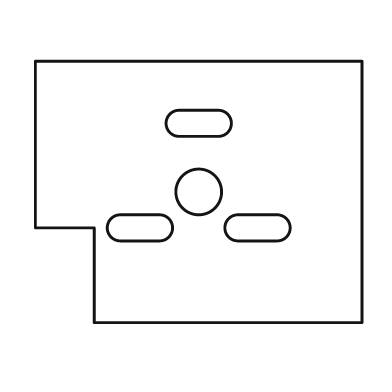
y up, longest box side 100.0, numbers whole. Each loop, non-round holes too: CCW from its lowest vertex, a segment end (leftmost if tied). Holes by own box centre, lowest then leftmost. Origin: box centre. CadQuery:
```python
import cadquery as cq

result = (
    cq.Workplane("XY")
    .moveTo(-32.0, -40.0)
    .lineTo(50.0, -40.0)
    .lineTo(50.0, 40.0)
    .lineTo(-50.0, 40.0)
    .lineTo(-50.0, -11.0)
    .lineTo(-32.0, -11.0)
    .close()
    .moveTo(-24.0, -15.0)
    .lineTo(-12.0, -15.0)
    .threePointArc((-8.0, -11.0), (-12.0, -7.0))
    .lineTo(-24.0, -7.0)
    .threePointArc((-28.0, -11.0), (-24.0, -15.0))
    .close()
    .moveTo(12.0, -15.0)
    .lineTo(24.0, -15.0)
    .threePointArc((28.0, -11.0), (24.0, -7.0))
    .lineTo(12.0, -7.0)
    .threePointArc((8.0, -11.0), (12.0, -15.0))
    .close()
    .moveTo(0.0, 0.0)
    .circle(7.0)
    .moveTo(-6.0, 17.0)
    .lineTo(6.0, 17.0)
    .threePointArc((10.0, 21.0), (6.0, 25.0))
    .lineTo(-6.0, 25.0)
    .threePointArc((-10.0, 21.0), (-6.0, 17.0))
    .close()
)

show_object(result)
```